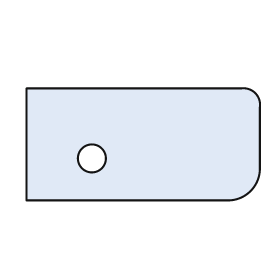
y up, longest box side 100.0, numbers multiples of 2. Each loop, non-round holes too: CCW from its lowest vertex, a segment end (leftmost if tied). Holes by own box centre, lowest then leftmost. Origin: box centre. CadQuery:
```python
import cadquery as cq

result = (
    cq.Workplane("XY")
    .moveTo(-50.0, -24.0)
    .lineTo(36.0, -24.0)
    .threePointArc((46.0, -20.0), (50.0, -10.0))
    .lineTo(50.0, 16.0)
    .threePointArc((48.0, 22.0), (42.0, 24.0))
    .lineTo(-50.0, 24.0)
    .close()
    .moveTo(-22.0, -6.0)
    .circle(6.0)
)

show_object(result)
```